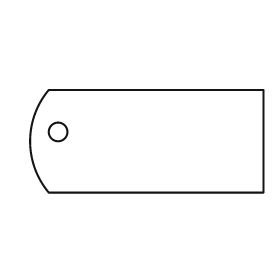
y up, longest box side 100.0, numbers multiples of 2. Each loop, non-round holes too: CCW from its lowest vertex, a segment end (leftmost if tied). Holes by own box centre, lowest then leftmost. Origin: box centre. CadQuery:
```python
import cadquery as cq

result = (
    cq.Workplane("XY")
    .moveTo(-42.0, -22.0)
    .lineTo(50.0, -22.0)
    .lineTo(50.0, 22.0)
    .lineTo(-42.0, 22.0)
    .threePointArc((-50.0, 0.0), (-42.0, -22.0))
    .close()
    .moveTo(-38.0, 4.0)
    .circle(4.0)
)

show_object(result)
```